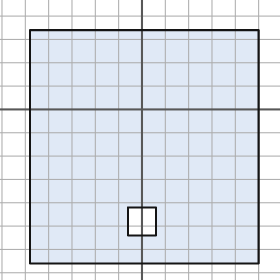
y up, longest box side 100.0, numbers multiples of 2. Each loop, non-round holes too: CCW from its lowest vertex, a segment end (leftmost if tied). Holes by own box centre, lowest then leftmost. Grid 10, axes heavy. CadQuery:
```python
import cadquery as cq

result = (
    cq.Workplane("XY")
    .moveTo(-48.0, -66.0)
    .lineTo(50.0, -66.0)
    .lineTo(50.0, 34.0)
    .lineTo(-48.0, 34.0)
    .close()
    .moveTo(-6.0, -54.0)
    .lineTo(6.0, -54.0)
    .lineTo(6.0, -42.0)
    .lineTo(-6.0, -42.0)
    .close()
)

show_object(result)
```